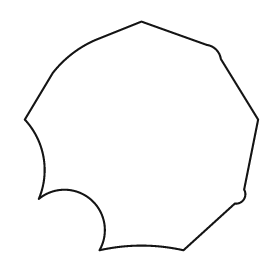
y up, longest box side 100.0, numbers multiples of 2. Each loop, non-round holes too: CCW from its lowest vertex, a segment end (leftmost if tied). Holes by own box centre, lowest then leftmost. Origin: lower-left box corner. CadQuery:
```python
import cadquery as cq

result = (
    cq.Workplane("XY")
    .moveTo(32.0, 0.0)
    .threePointArc((50.0, 2.0), (68.0, 0.0))
    .lineTo(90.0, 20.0)
    .threePointArc((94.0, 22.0), (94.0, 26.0))
    .lineTo(100.0, 56.0)
    .lineTo(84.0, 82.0)
    .threePointArc((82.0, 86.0), (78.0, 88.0))
    .lineTo(50.0, 98.0)
    .lineTo(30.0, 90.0)
    .threePointArc((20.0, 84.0), (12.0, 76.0))
    .lineTo(0.0, 56.0)
    .threePointArc((8.0, 40.0), (6.0, 22.0))
    .threePointArc((28.0, 22.0), (32.0, 0.0))
    .close()
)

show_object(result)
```